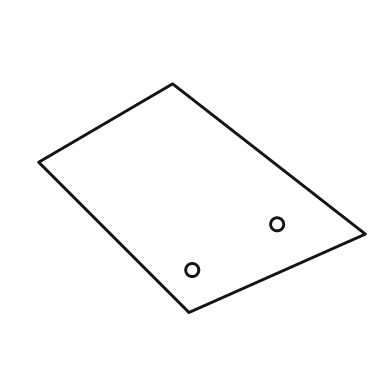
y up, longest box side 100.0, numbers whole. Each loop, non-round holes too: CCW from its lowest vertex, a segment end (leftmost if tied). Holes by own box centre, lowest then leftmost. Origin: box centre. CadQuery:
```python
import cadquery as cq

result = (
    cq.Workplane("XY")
    .moveTo(-4.0, -35.0)
    .lineTo(50.0, -11.0)
    .lineTo(-9.0, 35.0)
    .lineTo(-50.0, 11.0)
    .close()
    .moveTo(-3.0, -22.0)
    .circle(2.0)
    .moveTo(23.0, -8.0)
    .circle(2.0)
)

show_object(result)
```